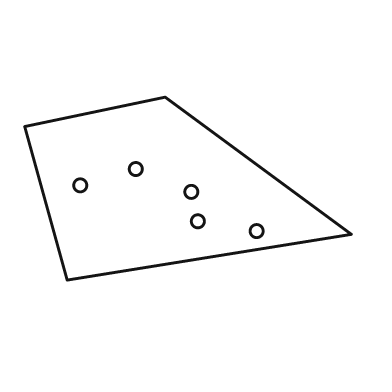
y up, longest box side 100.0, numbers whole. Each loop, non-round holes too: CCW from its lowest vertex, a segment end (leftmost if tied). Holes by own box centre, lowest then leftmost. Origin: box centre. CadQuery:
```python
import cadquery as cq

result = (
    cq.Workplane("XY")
    .moveTo(-37.0, -28.0)
    .lineTo(50.0, -14.0)
    .lineTo(-7.0, 28.0)
    .lineTo(-50.0, 19.0)
    .close()
    .moveTo(21.0, -13.0)
    .circle(2.0)
    .moveTo(3.0, -10.0)
    .circle(2.0)
    .moveTo(1.0, -1.0)
    .circle(2.0)
    .moveTo(-33.0, 1.0)
    .circle(2.0)
    .moveTo(-16.0, 6.0)
    .circle(2.0)
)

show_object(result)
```